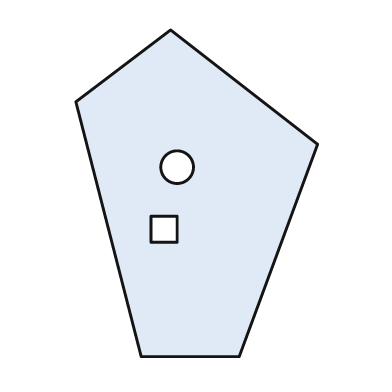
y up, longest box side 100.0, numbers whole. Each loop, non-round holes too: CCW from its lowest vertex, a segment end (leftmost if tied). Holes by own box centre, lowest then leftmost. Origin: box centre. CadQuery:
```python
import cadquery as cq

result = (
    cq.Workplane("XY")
    .moveTo(-17.0, -50.0)
    .lineTo(13.0, -50.0)
    .lineTo(37.0, 15.0)
    .lineTo(-8.0, 50.0)
    .lineTo(-37.0, 28.0)
    .close()
    .moveTo(-14.0, -15.0)
    .lineTo(-6.0, -15.0)
    .lineTo(-6.0, -7.0)
    .lineTo(-14.0, -7.0)
    .close()
    .moveTo(-6.0, 8.0)
    .circle(5.0)
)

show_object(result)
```